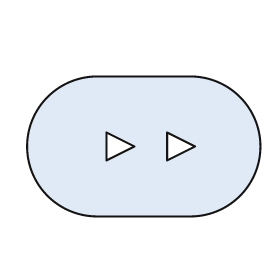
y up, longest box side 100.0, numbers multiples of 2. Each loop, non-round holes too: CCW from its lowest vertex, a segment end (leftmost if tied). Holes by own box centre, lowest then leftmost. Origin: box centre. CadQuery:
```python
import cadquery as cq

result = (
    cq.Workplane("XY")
    .moveTo(-20.0, -30.0)
    .lineTo(20.0, -30.0)
    .threePointArc((50.0, 0.0), (20.0, 30.0))
    .lineTo(-20.0, 30.0)
    .threePointArc((-50.0, 0.0), (-20.0, -30.0))
    .close()
    .moveTo(-16.0, -6.0)
    .lineTo(-4.0, 0.0)
    .lineTo(-16.0, 6.0)
    .close()
    .moveTo(10.0, -6.0)
    .lineTo(22.0, 0.0)
    .lineTo(10.0, 6.0)
    .close()
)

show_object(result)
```